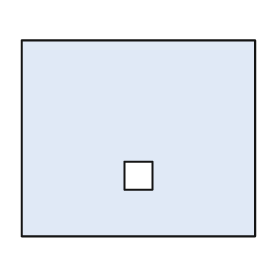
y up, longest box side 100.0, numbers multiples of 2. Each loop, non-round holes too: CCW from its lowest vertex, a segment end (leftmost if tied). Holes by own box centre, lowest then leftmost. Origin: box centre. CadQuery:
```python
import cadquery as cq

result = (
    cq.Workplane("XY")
    .moveTo(-50.0, -42.0)
    .lineTo(50.0, -42.0)
    .lineTo(50.0, 42.0)
    .lineTo(-50.0, 42.0)
    .close()
    .moveTo(-6.0, -22.0)
    .lineTo(6.0, -22.0)
    .lineTo(6.0, -10.0)
    .lineTo(-6.0, -10.0)
    .close()
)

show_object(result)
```